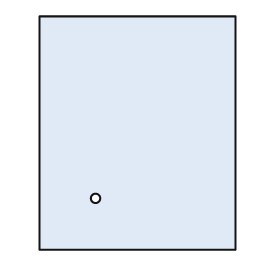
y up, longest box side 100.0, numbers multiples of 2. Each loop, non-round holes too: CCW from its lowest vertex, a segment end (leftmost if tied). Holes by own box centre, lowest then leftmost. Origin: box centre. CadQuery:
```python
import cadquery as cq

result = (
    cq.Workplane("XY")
    .moveTo(-42.0, -50.0)
    .lineTo(42.0, -50.0)
    .lineTo(42.0, 50.0)
    .lineTo(-42.0, 50.0)
    .close()
    .moveTo(-18.0, -28.0)
    .circle(2.0)
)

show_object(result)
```